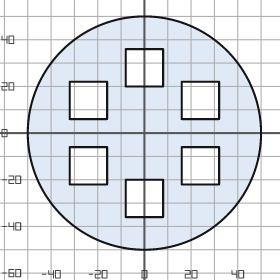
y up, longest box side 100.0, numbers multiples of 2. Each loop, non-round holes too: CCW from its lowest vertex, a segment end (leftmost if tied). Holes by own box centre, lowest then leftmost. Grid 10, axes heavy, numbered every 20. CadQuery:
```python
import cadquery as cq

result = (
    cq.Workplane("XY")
    .moveTo(0.0, 0.0)
    .circle(50.0)
    .moveTo(-8.0, -36.0)
    .lineTo(8.0, -36.0)
    .lineTo(8.0, -20.0)
    .lineTo(-8.0, -20.0)
    .close()
    .moveTo(-32.0, -22.0)
    .lineTo(-16.0, -22.0)
    .lineTo(-16.0, -6.0)
    .lineTo(-32.0, -6.0)
    .close()
    .moveTo(16.0, -22.0)
    .lineTo(32.0, -22.0)
    .lineTo(32.0, -6.0)
    .lineTo(16.0, -6.0)
    .close()
    .moveTo(-32.0, 6.0)
    .lineTo(-16.0, 6.0)
    .lineTo(-16.0, 22.0)
    .lineTo(-32.0, 22.0)
    .close()
    .moveTo(16.0, 6.0)
    .lineTo(32.0, 6.0)
    .lineTo(32.0, 22.0)
    .lineTo(16.0, 22.0)
    .close()
    .moveTo(-8.0, 20.0)
    .lineTo(8.0, 20.0)
    .lineTo(8.0, 36.0)
    .lineTo(-8.0, 36.0)
    .close()
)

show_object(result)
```